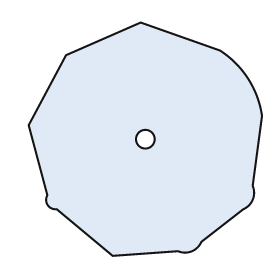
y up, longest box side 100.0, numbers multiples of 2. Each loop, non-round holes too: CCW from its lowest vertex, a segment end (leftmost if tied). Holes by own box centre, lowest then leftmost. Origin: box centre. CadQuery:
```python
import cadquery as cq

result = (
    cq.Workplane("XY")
    .moveTo(-14.0, -50.0)
    .lineTo(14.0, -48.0)
    .threePointArc((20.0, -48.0), (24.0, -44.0))
    .lineTo(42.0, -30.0)
    .threePointArc((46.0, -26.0), (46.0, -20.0))
    .lineTo(50.0, 10.0)
    .threePointArc((44.0, 26.0), (32.0, 38.0))
    .lineTo(-2.0, 50.0)
    .lineTo(-34.0, 36.0)
    .lineTo(-50.0, 6.0)
    .lineTo(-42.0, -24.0)
    .threePointArc((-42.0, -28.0), (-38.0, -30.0))
    .close()
    .moveTo(0.0, 0.0)
    .circle(4.0)
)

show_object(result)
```